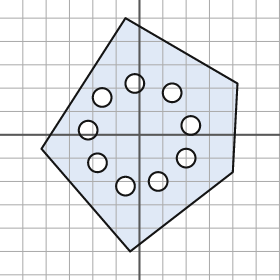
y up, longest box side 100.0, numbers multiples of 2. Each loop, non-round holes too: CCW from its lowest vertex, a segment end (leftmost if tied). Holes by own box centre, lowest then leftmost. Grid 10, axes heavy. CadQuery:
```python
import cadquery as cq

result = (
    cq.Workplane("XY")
    .moveTo(-4.0, -50.0)
    .lineTo(40.0, -16.0)
    .lineTo(42.0, 22.0)
    .lineTo(-6.0, 50.0)
    .lineTo(-42.0, -6.0)
    .close()
    .moveTo(-6.0, -22.0)
    .circle(4.0)
    .moveTo(8.0, -20.0)
    .circle(4.0)
    .moveTo(-18.0, -12.0)
    .circle(4.0)
    .moveTo(20.0, -10.0)
    .circle(4.0)
    .moveTo(-22.0, 2.0)
    .circle(4.0)
    .moveTo(22.0, 4.0)
    .circle(4.0)
    .moveTo(-16.0, 16.0)
    .circle(4.0)
    .moveTo(14.0, 18.0)
    .circle(4.0)
    .moveTo(-2.0, 22.0)
    .circle(4.0)
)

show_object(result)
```